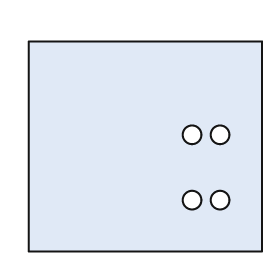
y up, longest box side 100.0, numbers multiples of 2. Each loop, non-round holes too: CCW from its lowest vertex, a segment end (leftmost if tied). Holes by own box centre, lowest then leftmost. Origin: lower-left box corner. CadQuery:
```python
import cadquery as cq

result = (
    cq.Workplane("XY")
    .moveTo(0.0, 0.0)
    .lineTo(100.0, 0.0)
    .lineTo(100.0, 90.0)
    .lineTo(0.0, 90.0)
    .close()
    .moveTo(70.0, 22.0)
    .circle(4.0)
    .moveTo(82.0, 22.0)
    .circle(4.0)
    .moveTo(70.0, 50.0)
    .circle(4.0)
    .moveTo(82.0, 50.0)
    .circle(4.0)
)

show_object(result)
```